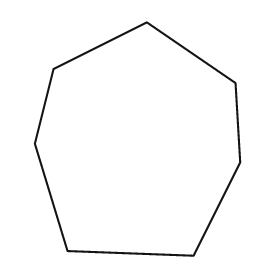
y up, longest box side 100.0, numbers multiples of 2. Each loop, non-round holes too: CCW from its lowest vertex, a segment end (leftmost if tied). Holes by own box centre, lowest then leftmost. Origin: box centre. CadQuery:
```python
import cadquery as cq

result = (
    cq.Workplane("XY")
    .moveTo(24.0, -50.0)
    .lineTo(44.0, -10.0)
    .lineTo(42.0, 24.0)
    .lineTo(4.0, 50.0)
    .lineTo(-36.0, 30.0)
    .lineTo(-44.0, -2.0)
    .lineTo(-30.0, -48.0)
    .close()
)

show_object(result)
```